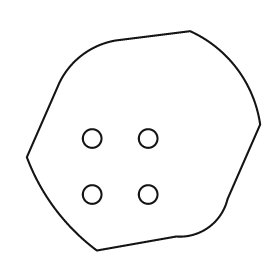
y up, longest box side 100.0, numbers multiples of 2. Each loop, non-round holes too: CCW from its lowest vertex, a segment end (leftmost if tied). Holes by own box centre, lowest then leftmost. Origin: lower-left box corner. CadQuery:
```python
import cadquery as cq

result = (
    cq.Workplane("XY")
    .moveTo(30.0, 0.0)
    .lineTo(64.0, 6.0)
    .threePointArc((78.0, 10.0), (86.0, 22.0))
    .lineTo(100.0, 54.0)
    .threePointArc((90.0, 78.0), (70.0, 94.0))
    .lineTo(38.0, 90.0)
    .threePointArc((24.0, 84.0), (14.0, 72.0))
    .lineTo(0.0, 40.0)
    .threePointArc((12.0, 18.0), (30.0, 0.0))
    .close()
    .moveTo(28.0, 24.0)
    .circle(4.0)
    .moveTo(52.0, 24.0)
    .circle(4.0)
    .moveTo(28.0, 48.0)
    .circle(4.0)
    .moveTo(52.0, 48.0)
    .circle(4.0)
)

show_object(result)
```